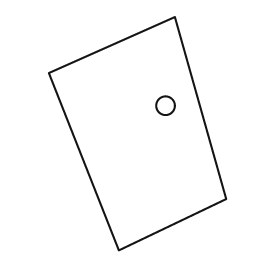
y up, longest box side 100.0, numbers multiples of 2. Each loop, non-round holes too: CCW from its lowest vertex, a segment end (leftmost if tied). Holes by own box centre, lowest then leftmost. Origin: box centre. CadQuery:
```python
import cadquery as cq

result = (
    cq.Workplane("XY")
    .moveTo(-8.0, -50.0)
    .lineTo(38.0, -28.0)
    .lineTo(16.0, 50.0)
    .lineTo(-38.0, 26.0)
    .close()
    .moveTo(12.0, 12.0)
    .circle(4.0)
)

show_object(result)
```